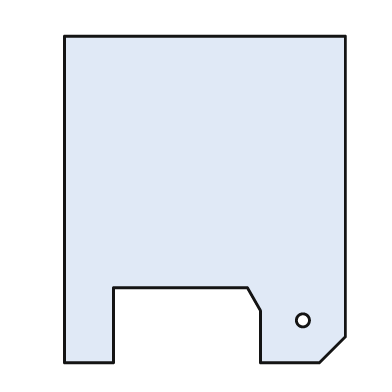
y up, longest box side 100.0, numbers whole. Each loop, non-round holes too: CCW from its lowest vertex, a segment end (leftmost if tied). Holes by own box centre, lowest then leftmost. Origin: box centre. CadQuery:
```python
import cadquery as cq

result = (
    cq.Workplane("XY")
    .moveTo(-43.0, -50.0)
    .lineTo(-28.0, -50.0)
    .lineTo(-28.0, -27.0)
    .lineTo(13.0, -27.0)
    .lineTo(17.0, -34.0)
    .lineTo(17.0, -50.0)
    .lineTo(35.0, -50.0)
    .lineTo(43.0, -42.0)
    .lineTo(43.0, 50.0)
    .lineTo(-43.0, 50.0)
    .close()
    .moveTo(30.0, -37.0)
    .circle(2.0)
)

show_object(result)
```